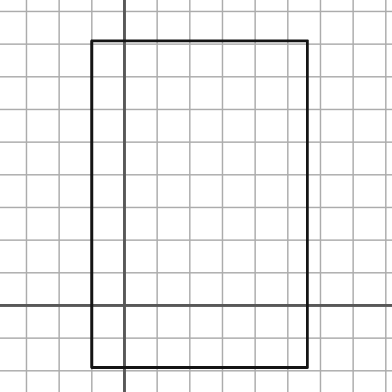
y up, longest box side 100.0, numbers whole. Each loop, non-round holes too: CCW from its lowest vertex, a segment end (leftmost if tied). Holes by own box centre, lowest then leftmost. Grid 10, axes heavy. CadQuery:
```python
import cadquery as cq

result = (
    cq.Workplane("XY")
    .moveTo(-10.0, -19.0)
    .lineTo(56.0, -19.0)
    .lineTo(56.0, 81.0)
    .lineTo(-10.0, 81.0)
    .close()
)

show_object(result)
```